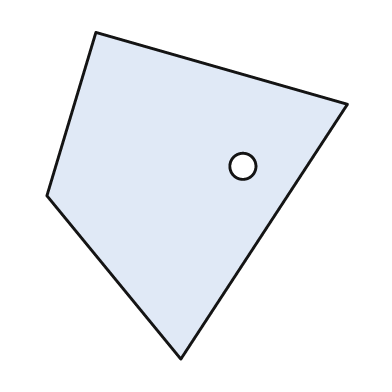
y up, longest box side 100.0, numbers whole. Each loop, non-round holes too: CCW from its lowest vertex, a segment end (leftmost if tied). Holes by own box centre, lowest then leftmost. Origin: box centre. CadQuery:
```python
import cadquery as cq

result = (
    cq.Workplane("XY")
    .moveTo(-5.0, -50.0)
    .lineTo(46.0, 28.0)
    .lineTo(-31.0, 50.0)
    .lineTo(-46.0, 0.0)
    .close()
    .moveTo(14.0, 9.0)
    .circle(4.0)
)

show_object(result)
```